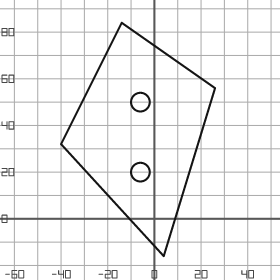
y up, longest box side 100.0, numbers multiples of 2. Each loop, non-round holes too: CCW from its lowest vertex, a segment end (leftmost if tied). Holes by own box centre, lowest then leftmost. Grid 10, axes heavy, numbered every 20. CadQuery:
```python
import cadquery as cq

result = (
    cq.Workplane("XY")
    .moveTo(4.0, -16.0)
    .lineTo(26.0, 56.0)
    .lineTo(-14.0, 84.0)
    .lineTo(-40.0, 32.0)
    .close()
    .moveTo(-6.0, 20.0)
    .circle(4.0)
    .moveTo(-6.0, 50.0)
    .circle(4.0)
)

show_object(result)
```